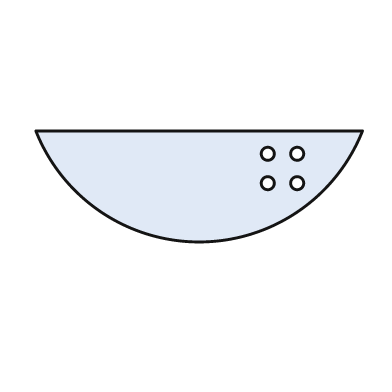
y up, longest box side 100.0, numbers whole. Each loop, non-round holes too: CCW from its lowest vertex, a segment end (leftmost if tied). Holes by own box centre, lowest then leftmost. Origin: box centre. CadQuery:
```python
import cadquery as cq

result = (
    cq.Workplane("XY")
    .moveTo(-50.0, 17.0)
    .threePointArc((0.0, -17.0), (50.0, 17.0))
    .close()
    .moveTo(21.0, 1.0)
    .circle(2.0)
    .moveTo(30.0, 1.0)
    .circle(2.0)
    .moveTo(21.0, 10.0)
    .circle(2.0)
    .moveTo(30.0, 10.0)
    .circle(2.0)
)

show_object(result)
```